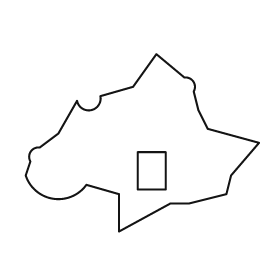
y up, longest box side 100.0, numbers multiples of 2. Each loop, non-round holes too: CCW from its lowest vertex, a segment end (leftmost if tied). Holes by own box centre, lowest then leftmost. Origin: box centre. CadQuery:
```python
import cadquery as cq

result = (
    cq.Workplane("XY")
    .moveTo(-10.0, -38.0)
    .lineTo(12.0, -26.0)
    .lineTo(20.0, -26.0)
    .lineTo(36.0, -22.0)
    .lineTo(38.0, -14.0)
    .lineTo(50.0, 0.0)
    .lineTo(28.0, 6.0)
    .lineTo(24.0, 14.0)
    .lineTo(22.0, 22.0)
    .threePointArc((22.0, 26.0), (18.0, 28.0))
    .lineTo(6.0, 38.0)
    .lineTo(-4.0, 24.0)
    .lineTo(-18.0, 20.0)
    .threePointArc((-22.0, 14.0), (-28.0, 18.0))
    .lineTo(-36.0, 4.0)
    .lineTo(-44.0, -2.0)
    .threePointArc((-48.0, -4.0), (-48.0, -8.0))
    .lineTo(-50.0, -14.0)
    .threePointArc((-38.0, -24.0), (-24.0, -18.0))
    .lineTo(-10.0, -22.0)
    .close()
    .moveTo(-2.0, -20.0)
    .lineTo(10.0, -20.0)
    .lineTo(10.0, -4.0)
    .lineTo(-2.0, -4.0)
    .close()
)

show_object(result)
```